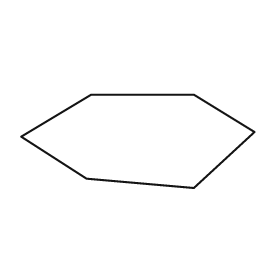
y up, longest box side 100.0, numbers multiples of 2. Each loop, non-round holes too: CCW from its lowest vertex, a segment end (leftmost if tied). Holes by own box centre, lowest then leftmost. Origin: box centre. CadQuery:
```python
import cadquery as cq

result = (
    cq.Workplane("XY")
    .moveTo(24.0, -20.0)
    .lineTo(50.0, 4.0)
    .lineTo(24.0, 20.0)
    .lineTo(-20.0, 20.0)
    .lineTo(-50.0, 2.0)
    .lineTo(-22.0, -16.0)
    .close()
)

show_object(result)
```